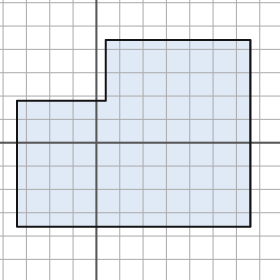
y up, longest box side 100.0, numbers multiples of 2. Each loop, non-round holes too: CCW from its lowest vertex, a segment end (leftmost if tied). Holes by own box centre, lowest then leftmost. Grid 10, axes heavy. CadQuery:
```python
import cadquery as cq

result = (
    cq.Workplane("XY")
    .moveTo(-34.0, -36.0)
    .lineTo(66.0, -36.0)
    .lineTo(66.0, 44.0)
    .lineTo(4.0, 44.0)
    .lineTo(4.0, 18.0)
    .lineTo(-34.0, 18.0)
    .close()
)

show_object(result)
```